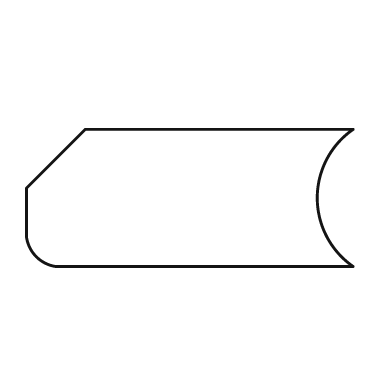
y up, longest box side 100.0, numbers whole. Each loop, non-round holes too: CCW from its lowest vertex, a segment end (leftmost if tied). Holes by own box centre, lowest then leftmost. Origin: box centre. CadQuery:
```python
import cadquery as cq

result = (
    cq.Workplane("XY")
    .moveTo(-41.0, -21.0)
    .lineTo(50.0, -21.0)
    .threePointArc((39.0, 0.0), (50.0, 21.0))
    .lineTo(-32.0, 21.0)
    .lineTo(-50.0, 3.0)
    .lineTo(-50.0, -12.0)
    .threePointArc((-47.0, -18.0), (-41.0, -21.0))
    .close()
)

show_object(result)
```